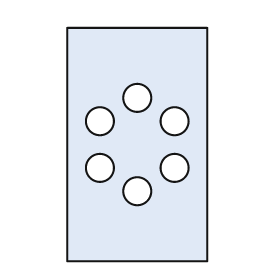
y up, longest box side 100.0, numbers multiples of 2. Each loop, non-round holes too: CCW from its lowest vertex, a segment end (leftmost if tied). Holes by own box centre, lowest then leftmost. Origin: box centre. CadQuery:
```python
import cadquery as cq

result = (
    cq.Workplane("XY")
    .moveTo(-30.0, -50.0)
    .lineTo(30.0, -50.0)
    .lineTo(30.0, 50.0)
    .lineTo(-30.0, 50.0)
    .close()
    .moveTo(0.0, -20.0)
    .circle(6.0)
    .moveTo(-16.0, -10.0)
    .circle(6.0)
    .moveTo(16.0, -10.0)
    .circle(6.0)
    .moveTo(-16.0, 10.0)
    .circle(6.0)
    .moveTo(16.0, 10.0)
    .circle(6.0)
    .moveTo(0.0, 20.0)
    .circle(6.0)
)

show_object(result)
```